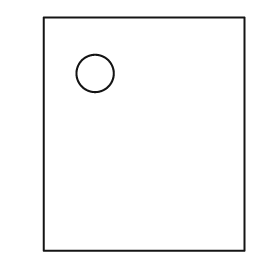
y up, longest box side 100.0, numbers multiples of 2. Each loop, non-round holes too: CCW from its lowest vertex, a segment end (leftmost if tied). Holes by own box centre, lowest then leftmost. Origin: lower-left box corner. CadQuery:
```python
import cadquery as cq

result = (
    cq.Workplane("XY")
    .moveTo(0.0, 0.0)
    .lineTo(86.0, 0.0)
    .lineTo(86.0, 100.0)
    .lineTo(0.0, 100.0)
    .close()
    .moveTo(22.0, 76.0)
    .circle(8.0)
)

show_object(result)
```